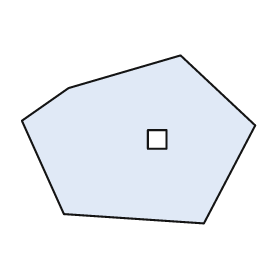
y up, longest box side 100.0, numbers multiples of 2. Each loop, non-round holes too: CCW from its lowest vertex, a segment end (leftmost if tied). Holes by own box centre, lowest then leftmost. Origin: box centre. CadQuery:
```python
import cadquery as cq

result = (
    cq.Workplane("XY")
    .moveTo(28.0, -36.0)
    .lineTo(50.0, 6.0)
    .lineTo(18.0, 36.0)
    .lineTo(-30.0, 22.0)
    .lineTo(-50.0, 8.0)
    .lineTo(-32.0, -32.0)
    .close()
    .moveTo(4.0, -4.0)
    .lineTo(12.0, -4.0)
    .lineTo(12.0, 4.0)
    .lineTo(4.0, 4.0)
    .close()
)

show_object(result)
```